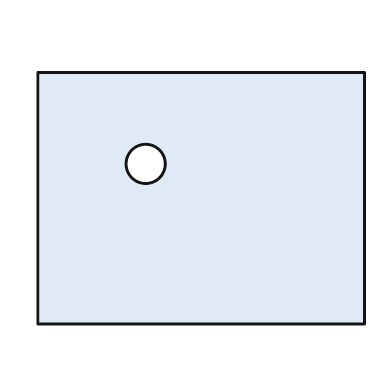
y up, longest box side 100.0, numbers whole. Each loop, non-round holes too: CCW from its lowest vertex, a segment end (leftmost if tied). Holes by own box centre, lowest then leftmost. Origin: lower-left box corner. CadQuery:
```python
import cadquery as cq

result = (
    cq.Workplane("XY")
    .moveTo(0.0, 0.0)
    .lineTo(100.0, 0.0)
    .lineTo(100.0, 77.0)
    .lineTo(0.0, 77.0)
    .close()
    .moveTo(33.0, 49.0)
    .circle(6.0)
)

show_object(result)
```